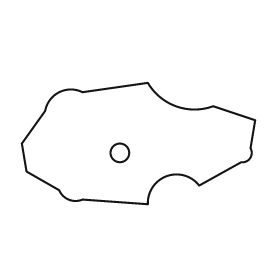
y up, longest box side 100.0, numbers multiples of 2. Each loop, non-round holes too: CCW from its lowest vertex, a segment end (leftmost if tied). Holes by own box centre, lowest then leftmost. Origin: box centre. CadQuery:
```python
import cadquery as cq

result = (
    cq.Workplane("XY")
    .moveTo(4.0, -26.0)
    .threePointArc((12.0, -14.0), (26.0, -18.0))
    .lineTo(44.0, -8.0)
    .threePointArc((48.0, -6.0), (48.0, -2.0))
    .lineTo(50.0, 10.0)
    .lineTo(32.0, 16.0)
    .threePointArc((16.0, 16.0), (4.0, 26.0))
    .lineTo(-24.0, 22.0)
    .threePointArc((-34.0, 22.0), (-40.0, 14.0))
    .lineTo(-50.0, 0.0)
    .lineTo(-48.0, -12.0)
    .lineTo(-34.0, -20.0)
    .threePointArc((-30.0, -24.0), (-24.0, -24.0))
    .close()
    .moveTo(-8.0, -4.0)
    .circle(4.0)
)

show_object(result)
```